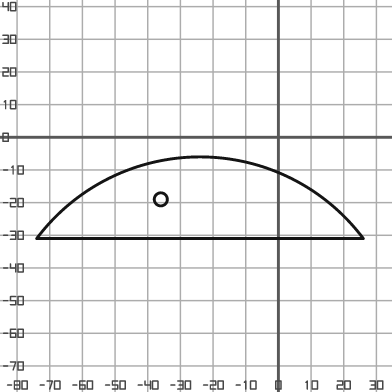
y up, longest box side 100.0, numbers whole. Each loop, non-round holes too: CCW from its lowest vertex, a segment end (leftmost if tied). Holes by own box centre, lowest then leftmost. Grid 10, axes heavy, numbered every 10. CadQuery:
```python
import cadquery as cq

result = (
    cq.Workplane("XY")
    .moveTo(-74.0, -31.0)
    .lineTo(26.0, -31.0)
    .threePointArc((-24.0, -6.0), (-74.0, -31.0))
    .close()
    .moveTo(-36.0, -19.0)
    .circle(2.0)
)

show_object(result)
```